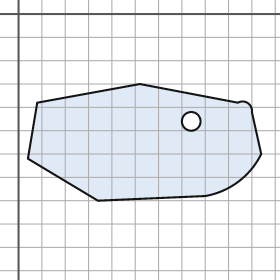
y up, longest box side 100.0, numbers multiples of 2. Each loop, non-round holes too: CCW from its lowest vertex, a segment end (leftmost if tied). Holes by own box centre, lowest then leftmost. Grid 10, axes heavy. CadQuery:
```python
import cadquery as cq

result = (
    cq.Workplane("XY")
    .moveTo(34.0, -80.0)
    .lineTo(80.0, -78.0)
    .threePointArc((94.0, -72.0), (104.0, -60.0))
    .lineTo(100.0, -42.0)
    .threePointArc((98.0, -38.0), (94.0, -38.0))
    .lineTo(52.0, -30.0)
    .lineTo(8.0, -38.0)
    .lineTo(4.0, -62.0)
    .close()
    .moveTo(74.0, -46.0)
    .circle(4.0)
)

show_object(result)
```